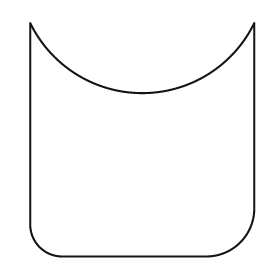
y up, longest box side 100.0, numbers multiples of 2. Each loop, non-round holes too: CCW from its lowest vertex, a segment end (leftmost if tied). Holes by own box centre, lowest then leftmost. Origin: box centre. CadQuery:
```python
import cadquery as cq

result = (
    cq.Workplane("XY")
    .moveTo(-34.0, -50.0)
    .lineTo(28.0, -50.0)
    .threePointArc((42.0, -44.0), (48.0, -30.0))
    .lineTo(48.0, 50.0)
    .threePointArc((0.0, 20.0), (-48.0, 50.0))
    .lineTo(-48.0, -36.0)
    .threePointArc((-44.0, -46.0), (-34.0, -50.0))
    .close()
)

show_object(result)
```